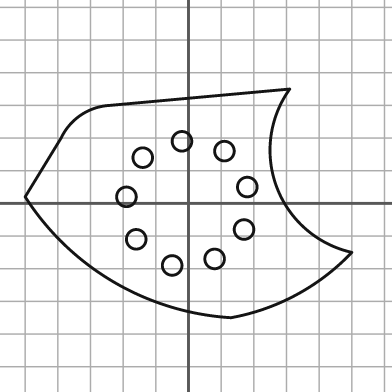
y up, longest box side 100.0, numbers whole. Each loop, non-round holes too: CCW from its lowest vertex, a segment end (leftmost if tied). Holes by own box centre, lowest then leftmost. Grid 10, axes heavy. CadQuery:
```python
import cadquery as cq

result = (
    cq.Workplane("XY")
    .moveTo(13.0, -35.0)
    .threePointArc((33.0, -28.0), (50.0, -15.0))
    .threePointArc((27.0, 5.0), (31.0, 35.0))
    .lineTo(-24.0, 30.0)
    .threePointArc((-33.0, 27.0), (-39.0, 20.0))
    .lineTo(-50.0, 2.0)
    .threePointArc((-23.0, -24.0), (13.0, -35.0))
    .close()
    .moveTo(-5.0, -19.0)
    .circle(3.0)
    .moveTo(8.0, -17.0)
    .circle(3.0)
    .moveTo(-16.0, -11.0)
    .circle(3.0)
    .moveTo(17.0, -8.0)
    .circle(3.0)
    .moveTo(-19.0, 2.0)
    .circle(3.0)
    .moveTo(18.0, 5.0)
    .circle(3.0)
    .moveTo(-14.0, 14.0)
    .circle(3.0)
    .moveTo(11.0, 16.0)
    .circle(3.0)
    .moveTo(-2.0, 19.0)
    .circle(3.0)
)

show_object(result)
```